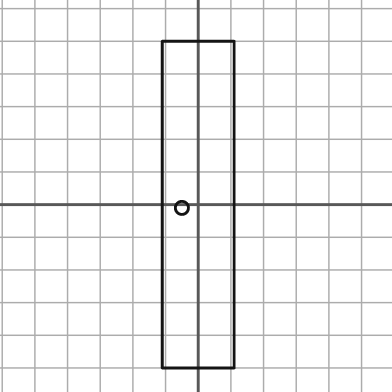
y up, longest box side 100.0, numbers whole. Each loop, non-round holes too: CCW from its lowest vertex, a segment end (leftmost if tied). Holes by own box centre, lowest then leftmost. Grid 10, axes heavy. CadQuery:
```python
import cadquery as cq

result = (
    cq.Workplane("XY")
    .moveTo(-11.0, -50.0)
    .lineTo(11.0, -50.0)
    .lineTo(11.0, 50.0)
    .lineTo(-11.0, 50.0)
    .close()
    .moveTo(-5.0, -1.0)
    .circle(2.0)
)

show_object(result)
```